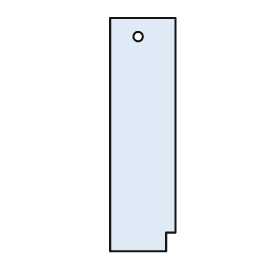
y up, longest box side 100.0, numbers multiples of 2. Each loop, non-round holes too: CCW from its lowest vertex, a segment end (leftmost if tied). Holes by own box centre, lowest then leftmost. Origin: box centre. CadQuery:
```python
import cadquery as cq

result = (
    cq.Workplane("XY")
    .moveTo(-14.0, -50.0)
    .lineTo(10.0, -50.0)
    .lineTo(10.0, -42.0)
    .lineTo(14.0, -42.0)
    .lineTo(14.0, 50.0)
    .lineTo(-14.0, 50.0)
    .close()
    .moveTo(-2.0, 42.0)
    .circle(2.0)
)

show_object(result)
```